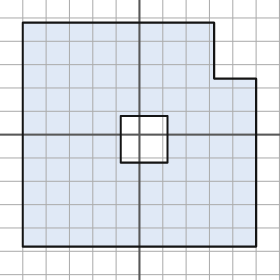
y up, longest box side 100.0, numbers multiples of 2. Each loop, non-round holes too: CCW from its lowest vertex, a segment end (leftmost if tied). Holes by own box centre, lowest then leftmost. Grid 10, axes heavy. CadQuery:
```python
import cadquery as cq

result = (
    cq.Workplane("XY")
    .moveTo(-50.0, -48.0)
    .lineTo(50.0, -48.0)
    .lineTo(50.0, 24.0)
    .lineTo(32.0, 24.0)
    .lineTo(32.0, 48.0)
    .lineTo(-50.0, 48.0)
    .close()
    .moveTo(-8.0, -12.0)
    .lineTo(12.0, -12.0)
    .lineTo(12.0, 8.0)
    .lineTo(-8.0, 8.0)
    .close()
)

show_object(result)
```